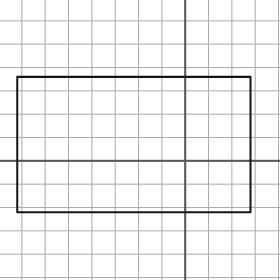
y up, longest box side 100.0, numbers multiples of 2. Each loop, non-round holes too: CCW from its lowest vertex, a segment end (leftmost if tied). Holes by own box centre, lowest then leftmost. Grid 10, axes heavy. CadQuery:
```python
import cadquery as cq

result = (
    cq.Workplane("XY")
    .moveTo(-72.0, -22.0)
    .lineTo(28.0, -22.0)
    .lineTo(28.0, 36.0)
    .lineTo(-72.0, 36.0)
    .close()
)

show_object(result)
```